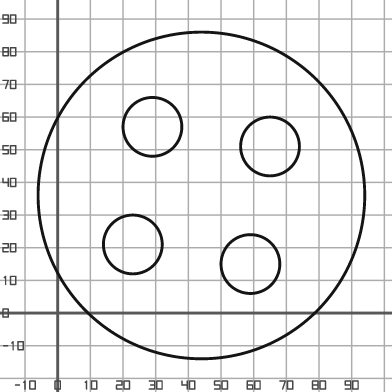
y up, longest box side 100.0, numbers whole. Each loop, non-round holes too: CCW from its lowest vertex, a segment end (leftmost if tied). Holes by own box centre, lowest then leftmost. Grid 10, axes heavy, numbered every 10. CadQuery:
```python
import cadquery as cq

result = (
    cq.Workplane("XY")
    .moveTo(44.0, 36.0)
    .circle(50.0)
    .moveTo(59.0, 15.0)
    .circle(9.0)
    .moveTo(23.0, 21.0)
    .circle(9.0)
    .moveTo(65.0, 51.0)
    .circle(9.0)
    .moveTo(29.0, 57.0)
    .circle(9.0)
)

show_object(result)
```